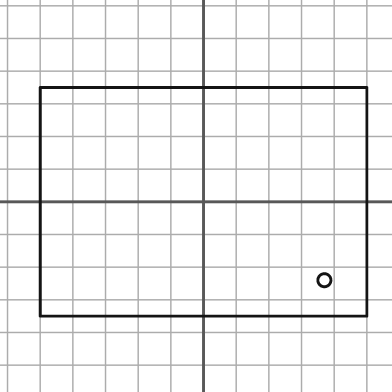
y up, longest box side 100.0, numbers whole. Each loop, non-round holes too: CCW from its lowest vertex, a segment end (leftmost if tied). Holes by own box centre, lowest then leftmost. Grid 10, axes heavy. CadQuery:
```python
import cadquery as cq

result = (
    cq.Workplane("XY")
    .moveTo(-50.0, -35.0)
    .lineTo(50.0, -35.0)
    .lineTo(50.0, 35.0)
    .lineTo(-50.0, 35.0)
    .close()
    .moveTo(37.0, -24.0)
    .circle(2.0)
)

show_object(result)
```